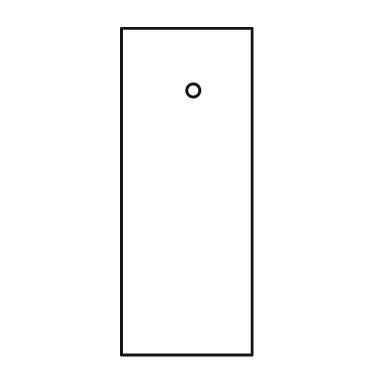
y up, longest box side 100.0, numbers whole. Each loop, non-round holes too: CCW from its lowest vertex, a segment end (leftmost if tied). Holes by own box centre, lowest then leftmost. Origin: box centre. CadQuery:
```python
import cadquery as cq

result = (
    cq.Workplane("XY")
    .moveTo(-20.0, -50.0)
    .lineTo(20.0, -50.0)
    .lineTo(20.0, 50.0)
    .lineTo(-20.0, 50.0)
    .close()
    .moveTo(2.0, 31.0)
    .circle(2.0)
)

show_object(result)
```